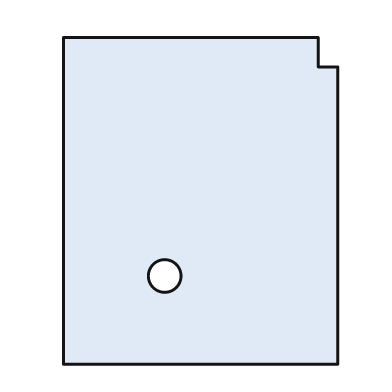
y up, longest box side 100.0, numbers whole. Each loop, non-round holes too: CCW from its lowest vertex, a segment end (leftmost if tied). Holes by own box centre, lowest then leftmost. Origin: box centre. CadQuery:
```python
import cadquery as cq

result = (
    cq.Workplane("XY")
    .moveTo(-42.0, -50.0)
    .lineTo(42.0, -50.0)
    .lineTo(42.0, 41.0)
    .lineTo(36.0, 41.0)
    .lineTo(36.0, 50.0)
    .lineTo(-42.0, 50.0)
    .close()
    .moveTo(-11.0, -23.0)
    .circle(5.0)
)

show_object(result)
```